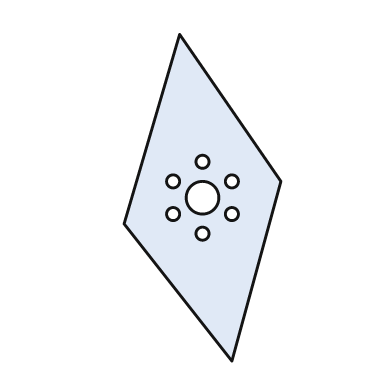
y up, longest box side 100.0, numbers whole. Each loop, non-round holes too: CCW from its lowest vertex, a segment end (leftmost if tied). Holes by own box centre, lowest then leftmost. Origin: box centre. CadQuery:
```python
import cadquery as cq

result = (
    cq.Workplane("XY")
    .moveTo(9.0, -50.0)
    .lineTo(24.0, 5.0)
    .lineTo(-7.0, 50.0)
    .lineTo(-24.0, -8.0)
    .close()
    .moveTo(0.0, -11.0)
    .circle(2.0)
    .moveTo(-9.0, -5.0)
    .circle(2.0)
    .moveTo(9.0, -5.0)
    .circle(2.0)
    .moveTo(0.0, 0.0)
    .circle(5.0)
    .moveTo(-9.0, 5.0)
    .circle(2.0)
    .moveTo(9.0, 5.0)
    .circle(2.0)
    .moveTo(0.0, 11.0)
    .circle(2.0)
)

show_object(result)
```